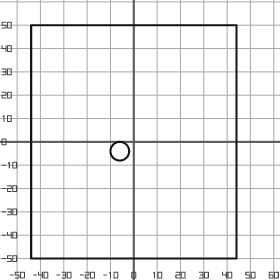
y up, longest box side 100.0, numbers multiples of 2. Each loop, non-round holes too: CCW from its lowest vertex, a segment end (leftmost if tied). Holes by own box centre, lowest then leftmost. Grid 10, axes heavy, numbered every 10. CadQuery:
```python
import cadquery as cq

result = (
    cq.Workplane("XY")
    .moveTo(-44.0, -50.0)
    .lineTo(44.0, -50.0)
    .lineTo(44.0, 50.0)
    .lineTo(-44.0, 50.0)
    .close()
    .moveTo(-6.0, -4.0)
    .circle(4.0)
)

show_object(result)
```